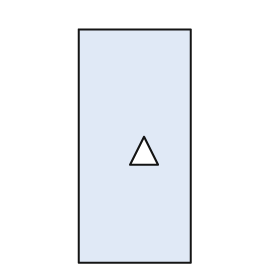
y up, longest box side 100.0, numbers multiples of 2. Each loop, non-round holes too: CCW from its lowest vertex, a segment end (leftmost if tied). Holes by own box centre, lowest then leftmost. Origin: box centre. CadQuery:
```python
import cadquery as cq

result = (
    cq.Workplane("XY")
    .moveTo(-24.0, -50.0)
    .lineTo(24.0, -50.0)
    .lineTo(24.0, 50.0)
    .lineTo(-24.0, 50.0)
    .close()
    .moveTo(-2.0, -8.0)
    .lineTo(10.0, -8.0)
    .lineTo(4.0, 4.0)
    .close()
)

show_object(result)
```